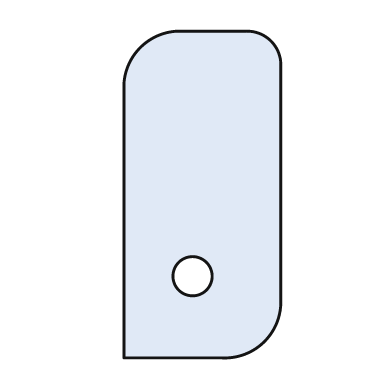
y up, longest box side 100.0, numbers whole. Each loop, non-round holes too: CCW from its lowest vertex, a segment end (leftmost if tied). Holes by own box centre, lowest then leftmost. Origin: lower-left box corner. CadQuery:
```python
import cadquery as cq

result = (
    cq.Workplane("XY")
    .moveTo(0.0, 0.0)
    .lineTo(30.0, 0.0)
    .threePointArc((43.0, 5.0), (48.0, 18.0))
    .lineTo(48.0, 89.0)
    .threePointArc((45.0, 97.0), (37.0, 100.0))
    .lineTo(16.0, 100.0)
    .threePointArc((5.0, 95.0), (0.0, 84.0))
    .close()
    .moveTo(21.0, 25.0)
    .circle(6.0)
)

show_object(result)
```